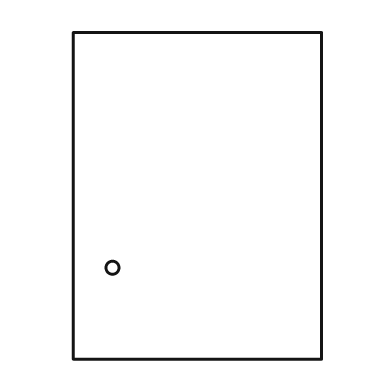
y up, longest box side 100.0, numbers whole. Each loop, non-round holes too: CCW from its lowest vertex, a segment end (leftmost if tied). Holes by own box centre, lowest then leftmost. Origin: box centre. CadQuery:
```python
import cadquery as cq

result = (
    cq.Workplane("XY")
    .moveTo(-38.0, -50.0)
    .lineTo(38.0, -50.0)
    .lineTo(38.0, 50.0)
    .lineTo(-38.0, 50.0)
    .close()
    .moveTo(-26.0, -22.0)
    .circle(2.0)
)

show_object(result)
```